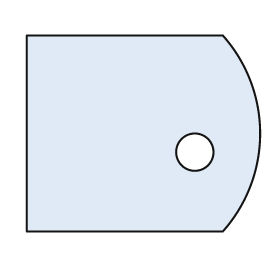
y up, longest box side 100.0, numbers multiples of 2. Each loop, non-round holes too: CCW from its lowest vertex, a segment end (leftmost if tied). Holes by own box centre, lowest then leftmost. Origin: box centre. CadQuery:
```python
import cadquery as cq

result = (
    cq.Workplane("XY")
    .moveTo(-50.0, -42.0)
    .lineTo(34.0, -42.0)
    .threePointArc((50.0, 0.0), (34.0, 42.0))
    .lineTo(-50.0, 42.0)
    .close()
    .moveTo(22.0, -8.0)
    .circle(8.0)
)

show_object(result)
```